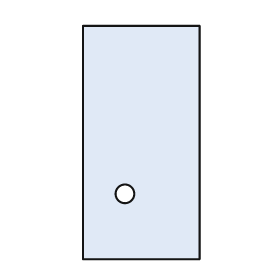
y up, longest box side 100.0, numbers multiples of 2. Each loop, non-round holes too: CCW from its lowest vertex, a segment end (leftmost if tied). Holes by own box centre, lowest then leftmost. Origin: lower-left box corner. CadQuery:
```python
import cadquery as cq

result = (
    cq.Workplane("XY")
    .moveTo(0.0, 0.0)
    .lineTo(50.0, 0.0)
    .lineTo(50.0, 100.0)
    .lineTo(0.0, 100.0)
    .close()
    .moveTo(18.0, 28.0)
    .circle(4.0)
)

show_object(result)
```